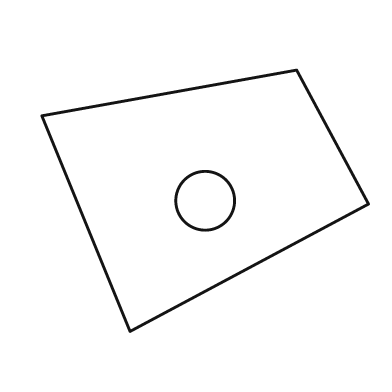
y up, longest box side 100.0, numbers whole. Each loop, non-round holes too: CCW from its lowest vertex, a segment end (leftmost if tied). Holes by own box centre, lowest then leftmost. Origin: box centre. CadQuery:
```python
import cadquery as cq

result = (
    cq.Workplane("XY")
    .moveTo(-23.0, -40.0)
    .lineTo(50.0, -1.0)
    .lineTo(28.0, 40.0)
    .lineTo(-50.0, 26.0)
    .close()
    .moveTo(0.0, 0.0)
    .circle(9.0)
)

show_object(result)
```